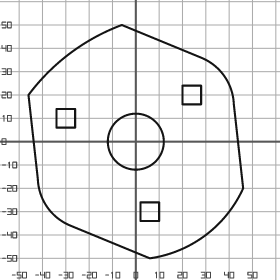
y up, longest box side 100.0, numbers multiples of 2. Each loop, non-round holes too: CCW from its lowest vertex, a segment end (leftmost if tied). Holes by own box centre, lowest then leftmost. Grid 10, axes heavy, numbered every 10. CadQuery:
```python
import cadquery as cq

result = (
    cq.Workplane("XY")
    .moveTo(6.0, -50.0)
    .threePointArc((30.0, -40.0), (46.0, -20.0))
    .lineTo(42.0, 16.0)
    .threePointArc((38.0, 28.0), (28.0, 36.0))
    .lineTo(-6.0, 50.0)
    .threePointArc((-28.0, 38.0), (-46.0, 20.0))
    .lineTo(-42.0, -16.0)
    .threePointArc((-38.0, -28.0), (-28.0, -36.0))
    .close()
    .moveTo(2.0, -34.0)
    .lineTo(10.0, -34.0)
    .lineTo(10.0, -26.0)
    .lineTo(2.0, -26.0)
    .close()
    .moveTo(0.0, 0.0)
    .circle(12.0)
    .moveTo(-34.0, 6.0)
    .lineTo(-26.0, 6.0)
    .lineTo(-26.0, 14.0)
    .lineTo(-34.0, 14.0)
    .close()
    .moveTo(20.0, 16.0)
    .lineTo(28.0, 16.0)
    .lineTo(28.0, 24.0)
    .lineTo(20.0, 24.0)
    .close()
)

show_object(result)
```